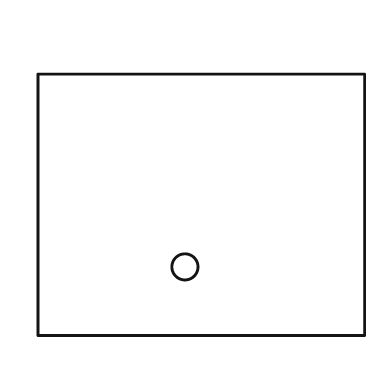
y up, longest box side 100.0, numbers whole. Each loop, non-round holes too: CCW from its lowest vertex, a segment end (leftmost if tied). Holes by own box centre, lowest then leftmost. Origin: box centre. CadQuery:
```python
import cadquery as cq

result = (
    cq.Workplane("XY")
    .moveTo(-50.0, -40.0)
    .lineTo(50.0, -40.0)
    .lineTo(50.0, 40.0)
    .lineTo(-50.0, 40.0)
    .close()
    .moveTo(-5.0, -19.0)
    .circle(4.0)
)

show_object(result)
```